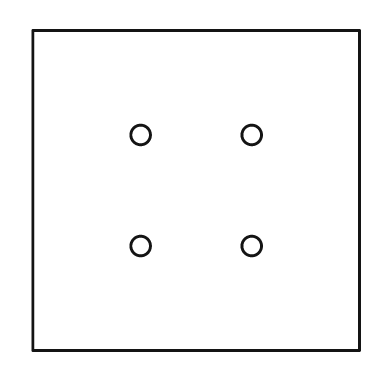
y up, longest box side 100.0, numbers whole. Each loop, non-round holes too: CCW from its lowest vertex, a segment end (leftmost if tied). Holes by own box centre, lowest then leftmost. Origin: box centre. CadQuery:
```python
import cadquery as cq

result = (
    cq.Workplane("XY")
    .moveTo(-50.0, -49.0)
    .lineTo(50.0, -49.0)
    .lineTo(50.0, 49.0)
    .lineTo(-50.0, 49.0)
    .close()
    .moveTo(-17.0, -17.0)
    .circle(3.0)
    .moveTo(17.0, -17.0)
    .circle(3.0)
    .moveTo(-17.0, 17.0)
    .circle(3.0)
    .moveTo(17.0, 17.0)
    .circle(3.0)
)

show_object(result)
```